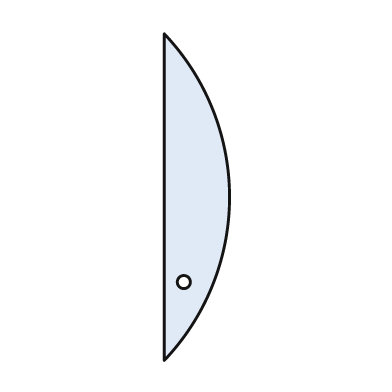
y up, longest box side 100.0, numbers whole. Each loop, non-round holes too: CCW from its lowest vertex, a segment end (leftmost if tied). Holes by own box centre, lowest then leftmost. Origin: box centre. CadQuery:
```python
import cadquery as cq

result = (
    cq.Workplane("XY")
    .moveTo(-10.0, -50.0)
    .threePointArc((10.0, 0.0), (-10.0, 50.0))
    .close()
    .moveTo(-4.0, -26.0)
    .circle(2.0)
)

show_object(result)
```